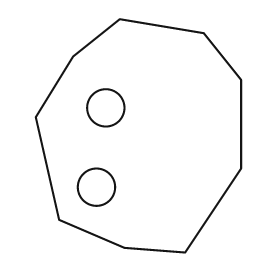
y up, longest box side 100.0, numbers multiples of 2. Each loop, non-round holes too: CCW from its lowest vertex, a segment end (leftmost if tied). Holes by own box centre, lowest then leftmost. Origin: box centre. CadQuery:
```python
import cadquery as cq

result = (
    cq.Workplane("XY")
    .moveTo(20.0, -50.0)
    .lineTo(44.0, -14.0)
    .lineTo(44.0, 24.0)
    .lineTo(28.0, 44.0)
    .lineTo(-8.0, 50.0)
    .lineTo(-28.0, 34.0)
    .lineTo(-44.0, 8.0)
    .lineTo(-34.0, -36.0)
    .lineTo(-6.0, -48.0)
    .close()
    .moveTo(-18.0, -22.0)
    .circle(8.0)
    .moveTo(-14.0, 12.0)
    .circle(8.0)
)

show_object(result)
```